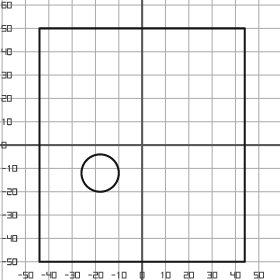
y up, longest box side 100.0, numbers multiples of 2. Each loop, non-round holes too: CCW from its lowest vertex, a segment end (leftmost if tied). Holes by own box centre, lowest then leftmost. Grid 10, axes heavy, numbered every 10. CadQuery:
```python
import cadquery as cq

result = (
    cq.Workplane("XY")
    .moveTo(-44.0, -50.0)
    .lineTo(44.0, -50.0)
    .lineTo(44.0, 50.0)
    .lineTo(-44.0, 50.0)
    .close()
    .moveTo(-18.0, -12.0)
    .circle(8.0)
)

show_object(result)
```